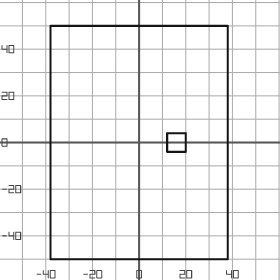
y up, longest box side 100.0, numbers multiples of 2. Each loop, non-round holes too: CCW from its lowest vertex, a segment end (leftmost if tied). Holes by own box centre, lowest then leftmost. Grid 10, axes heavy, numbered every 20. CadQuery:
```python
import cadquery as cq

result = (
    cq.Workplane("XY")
    .moveTo(-38.0, -50.0)
    .lineTo(38.0, -50.0)
    .lineTo(38.0, 50.0)
    .lineTo(-38.0, 50.0)
    .close()
    .moveTo(12.0, -4.0)
    .lineTo(20.0, -4.0)
    .lineTo(20.0, 4.0)
    .lineTo(12.0, 4.0)
    .close()
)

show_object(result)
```